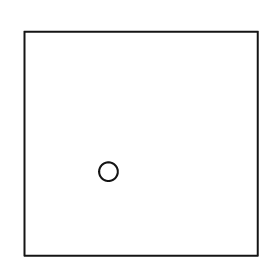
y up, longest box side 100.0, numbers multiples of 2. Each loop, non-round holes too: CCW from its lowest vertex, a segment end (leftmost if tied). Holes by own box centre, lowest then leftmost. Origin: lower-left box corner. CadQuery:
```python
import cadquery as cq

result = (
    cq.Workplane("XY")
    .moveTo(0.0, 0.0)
    .lineTo(100.0, 0.0)
    .lineTo(100.0, 96.0)
    .lineTo(0.0, 96.0)
    .close()
    .moveTo(36.0, 36.0)
    .circle(4.0)
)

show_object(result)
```